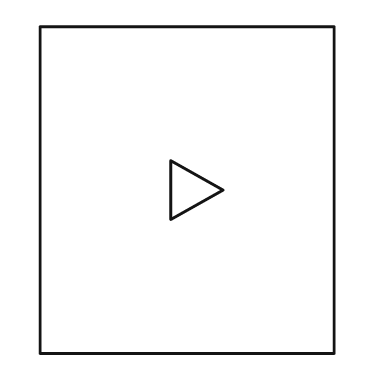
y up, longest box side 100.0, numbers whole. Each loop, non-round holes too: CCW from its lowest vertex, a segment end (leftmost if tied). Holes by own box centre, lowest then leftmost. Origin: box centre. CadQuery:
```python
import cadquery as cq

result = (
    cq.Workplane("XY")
    .moveTo(-45.0, -50.0)
    .lineTo(45.0, -50.0)
    .lineTo(45.0, 50.0)
    .lineTo(-45.0, 50.0)
    .close()
    .moveTo(-5.0, -9.0)
    .lineTo(11.0, 0.0)
    .lineTo(-5.0, 9.0)
    .close()
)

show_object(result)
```